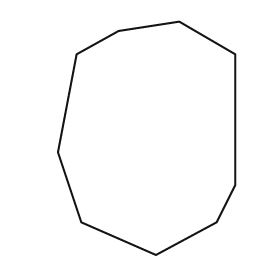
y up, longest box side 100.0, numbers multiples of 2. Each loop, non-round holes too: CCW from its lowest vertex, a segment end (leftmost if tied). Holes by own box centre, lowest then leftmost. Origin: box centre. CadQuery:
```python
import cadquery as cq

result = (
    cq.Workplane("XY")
    .moveTo(4.0, -50.0)
    .lineTo(30.0, -36.0)
    .lineTo(38.0, -20.0)
    .lineTo(38.0, 36.0)
    .lineTo(14.0, 50.0)
    .lineTo(-12.0, 46.0)
    .lineTo(-30.0, 36.0)
    .lineTo(-38.0, -6.0)
    .lineTo(-28.0, -36.0)
    .close()
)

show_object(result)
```